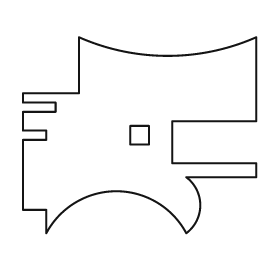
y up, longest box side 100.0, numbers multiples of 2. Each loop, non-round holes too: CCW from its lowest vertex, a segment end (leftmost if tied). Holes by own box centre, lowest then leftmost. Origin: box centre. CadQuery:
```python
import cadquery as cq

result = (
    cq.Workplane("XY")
    .moveTo(-40.0, -42.0)
    .threePointArc((-10.0, -24.0), (20.0, -42.0))
    .threePointArc((26.0, -30.0), (20.0, -18.0))
    .lineTo(50.0, -18.0)
    .lineTo(50.0, -12.0)
    .lineTo(14.0, -12.0)
    .lineTo(14.0, 6.0)
    .lineTo(50.0, 6.0)
    .lineTo(50.0, 42.0)
    .threePointArc((12.0, 34.0), (-26.0, 42.0))
    .lineTo(-26.0, 18.0)
    .lineTo(-50.0, 18.0)
    .lineTo(-50.0, 14.0)
    .lineTo(-36.0, 14.0)
    .lineTo(-36.0, 10.0)
    .lineTo(-50.0, 10.0)
    .lineTo(-50.0, 2.0)
    .lineTo(-40.0, 2.0)
    .lineTo(-40.0, -2.0)
    .lineTo(-50.0, -2.0)
    .lineTo(-50.0, -32.0)
    .lineTo(-40.0, -32.0)
    .close()
    .moveTo(-4.0, -4.0)
    .lineTo(4.0, -4.0)
    .lineTo(4.0, 4.0)
    .lineTo(-4.0, 4.0)
    .close()
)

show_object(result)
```